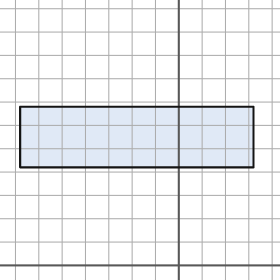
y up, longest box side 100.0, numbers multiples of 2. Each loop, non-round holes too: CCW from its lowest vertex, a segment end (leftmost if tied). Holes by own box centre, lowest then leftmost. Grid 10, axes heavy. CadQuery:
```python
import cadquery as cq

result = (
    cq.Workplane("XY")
    .moveTo(-68.0, 42.0)
    .lineTo(32.0, 42.0)
    .lineTo(32.0, 68.0)
    .lineTo(-68.0, 68.0)
    .close()
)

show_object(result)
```